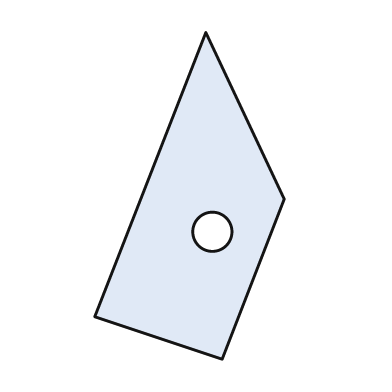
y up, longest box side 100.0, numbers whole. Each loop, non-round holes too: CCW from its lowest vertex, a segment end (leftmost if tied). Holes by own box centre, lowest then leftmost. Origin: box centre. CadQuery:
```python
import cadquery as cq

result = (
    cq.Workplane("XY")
    .moveTo(10.0, -50.0)
    .lineTo(29.0, -1.0)
    .lineTo(5.0, 50.0)
    .lineTo(-29.0, -37.0)
    .close()
    .moveTo(7.0, -11.0)
    .circle(6.0)
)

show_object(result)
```